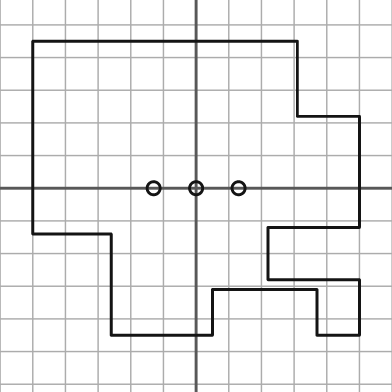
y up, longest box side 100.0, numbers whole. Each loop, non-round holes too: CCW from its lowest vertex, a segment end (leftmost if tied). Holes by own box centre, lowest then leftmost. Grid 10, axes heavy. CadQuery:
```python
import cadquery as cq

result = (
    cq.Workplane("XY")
    .moveTo(-26.0, -45.0)
    .lineTo(5.0, -45.0)
    .lineTo(5.0, -31.0)
    .lineTo(37.0, -31.0)
    .lineTo(37.0, -45.0)
    .lineTo(50.0, -45.0)
    .lineTo(50.0, -28.0)
    .lineTo(22.0, -28.0)
    .lineTo(22.0, -12.0)
    .lineTo(50.0, -12.0)
    .lineTo(50.0, 22.0)
    .lineTo(31.0, 22.0)
    .lineTo(31.0, 45.0)
    .lineTo(-50.0, 45.0)
    .lineTo(-50.0, -14.0)
    .lineTo(-26.0, -14.0)
    .close()
    .moveTo(-13.0, 0.0)
    .circle(2.0)
    .moveTo(0.0, 0.0)
    .circle(2.0)
    .moveTo(13.0, 0.0)
    .circle(2.0)
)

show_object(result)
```